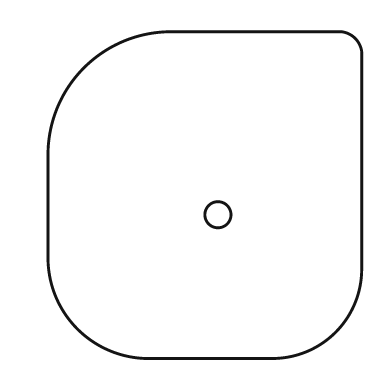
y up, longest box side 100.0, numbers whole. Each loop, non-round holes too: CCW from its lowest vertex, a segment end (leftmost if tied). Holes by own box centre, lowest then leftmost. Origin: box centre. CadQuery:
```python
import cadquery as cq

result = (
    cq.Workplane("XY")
    .moveTo(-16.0, -50.0)
    .lineTo(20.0, -50.0)
    .threePointArc((40.0, -42.0), (48.0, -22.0))
    .lineTo(48.0, 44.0)
    .threePointArc((46.0, 48.0), (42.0, 50.0))
    .lineTo(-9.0, 50.0)
    .threePointArc((-37.0, 39.0), (-48.0, 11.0))
    .lineTo(-48.0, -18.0)
    .threePointArc((-39.0, -41.0), (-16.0, -50.0))
    .close()
    .moveTo(4.0, -6.0)
    .circle(4.0)
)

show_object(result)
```